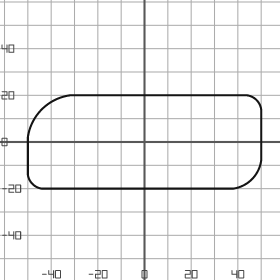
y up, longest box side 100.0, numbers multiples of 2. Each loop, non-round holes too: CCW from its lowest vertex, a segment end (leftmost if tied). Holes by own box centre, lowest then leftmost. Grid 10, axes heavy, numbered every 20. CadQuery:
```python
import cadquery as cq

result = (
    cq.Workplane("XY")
    .moveTo(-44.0, -20.0)
    .lineTo(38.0, -20.0)
    .threePointArc((46.0, -16.0), (50.0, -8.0))
    .lineTo(50.0, 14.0)
    .threePointArc((48.0, 18.0), (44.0, 20.0))
    .lineTo(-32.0, 20.0)
    .threePointArc((-44.0, 14.0), (-50.0, 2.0))
    .lineTo(-50.0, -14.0)
    .threePointArc((-48.0, -18.0), (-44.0, -20.0))
    .close()
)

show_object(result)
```